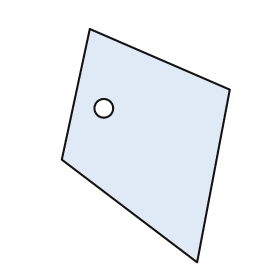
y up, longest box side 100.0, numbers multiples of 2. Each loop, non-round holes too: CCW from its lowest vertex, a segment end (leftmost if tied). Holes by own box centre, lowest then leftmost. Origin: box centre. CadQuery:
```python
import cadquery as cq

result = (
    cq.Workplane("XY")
    .moveTo(22.0, -50.0)
    .lineTo(36.0, 24.0)
    .lineTo(-24.0, 50.0)
    .lineTo(-36.0, -6.0)
    .close()
    .moveTo(-18.0, 16.0)
    .circle(4.0)
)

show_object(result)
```